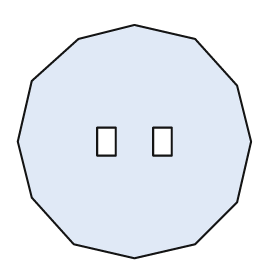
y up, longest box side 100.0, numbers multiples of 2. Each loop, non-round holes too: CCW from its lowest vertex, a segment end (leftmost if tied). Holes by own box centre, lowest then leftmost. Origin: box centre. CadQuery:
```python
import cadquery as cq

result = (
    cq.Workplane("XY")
    .moveTo(0.0, -50.0)
    .lineTo(26.0, -44.0)
    .lineTo(44.0, -26.0)
    .lineTo(50.0, 0.0)
    .lineTo(44.0, 24.0)
    .lineTo(26.0, 44.0)
    .lineTo(0.0, 50.0)
    .lineTo(-24.0, 44.0)
    .lineTo(-44.0, 26.0)
    .lineTo(-50.0, 0.0)
    .lineTo(-44.0, -24.0)
    .lineTo(-26.0, -44.0)
    .close()
    .moveTo(-16.0, -6.0)
    .lineTo(-8.0, -6.0)
    .lineTo(-8.0, 6.0)
    .lineTo(-16.0, 6.0)
    .close()
    .moveTo(8.0, -6.0)
    .lineTo(16.0, -6.0)
    .lineTo(16.0, 6.0)
    .lineTo(8.0, 6.0)
    .close()
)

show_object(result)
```